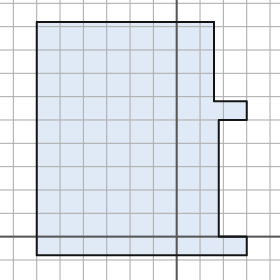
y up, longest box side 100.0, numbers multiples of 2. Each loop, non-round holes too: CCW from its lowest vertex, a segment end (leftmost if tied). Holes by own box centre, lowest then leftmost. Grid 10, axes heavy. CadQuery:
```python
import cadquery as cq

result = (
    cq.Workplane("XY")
    .moveTo(-60.0, -8.0)
    .lineTo(30.0, -8.0)
    .lineTo(30.0, 0.0)
    .lineTo(18.0, 0.0)
    .lineTo(18.0, 50.0)
    .lineTo(30.0, 50.0)
    .lineTo(30.0, 58.0)
    .lineTo(16.0, 58.0)
    .lineTo(16.0, 92.0)
    .lineTo(-60.0, 92.0)
    .close()
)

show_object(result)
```